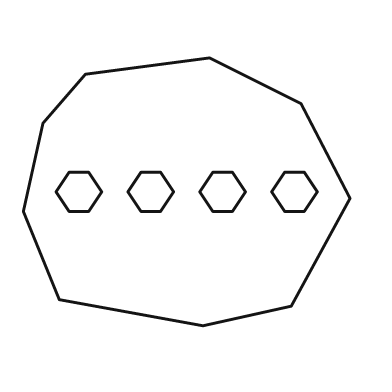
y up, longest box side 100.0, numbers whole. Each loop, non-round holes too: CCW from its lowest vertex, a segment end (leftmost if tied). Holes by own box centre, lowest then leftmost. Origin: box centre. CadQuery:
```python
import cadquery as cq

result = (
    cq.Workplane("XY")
    .moveTo(5.0, -41.0)
    .lineTo(32.0, -35.0)
    .lineTo(50.0, -2.0)
    .lineTo(35.0, 27.0)
    .lineTo(7.0, 41.0)
    .lineTo(-31.0, 36.0)
    .lineTo(-44.0, 21.0)
    .lineTo(-50.0, -6.0)
    .lineTo(-39.0, -33.0)
    .close()
    .moveTo(-36.0, -6.0)
    .lineTo(-30.0, -6.0)
    .lineTo(-26.0, 0.0)
    .lineTo(-30.0, 6.0)
    .lineTo(-36.0, 6.0)
    .lineTo(-40.0, 0.0)
    .close()
    .moveTo(-14.0, -6.0)
    .lineTo(-8.0, -6.0)
    .lineTo(-4.0, 0.0)
    .lineTo(-8.0, 6.0)
    .lineTo(-14.0, 6.0)
    .lineTo(-18.0, 0.0)
    .close()
    .moveTo(8.0, -6.0)
    .lineTo(14.0, -6.0)
    .lineTo(18.0, 0.0)
    .lineTo(14.0, 6.0)
    .lineTo(8.0, 6.0)
    .lineTo(4.0, 0.0)
    .close()
    .moveTo(30.0, -6.0)
    .lineTo(36.0, -6.0)
    .lineTo(40.0, 0.0)
    .lineTo(36.0, 6.0)
    .lineTo(30.0, 6.0)
    .lineTo(26.0, 0.0)
    .close()
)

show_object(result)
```